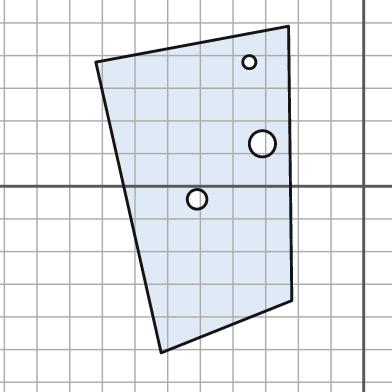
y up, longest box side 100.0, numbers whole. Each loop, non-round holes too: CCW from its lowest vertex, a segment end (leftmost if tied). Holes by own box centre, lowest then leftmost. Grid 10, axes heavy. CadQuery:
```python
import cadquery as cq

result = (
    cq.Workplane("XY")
    .moveTo(-62.0, -51.0)
    .lineTo(-22.0, -35.0)
    .lineTo(-23.0, 49.0)
    .lineTo(-82.0, 38.0)
    .close()
    .moveTo(-51.0, -4.0)
    .circle(3.0)
    .moveTo(-31.0, 13.0)
    .circle(4.0)
    .moveTo(-35.0, 38.0)
    .circle(2.0)
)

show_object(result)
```